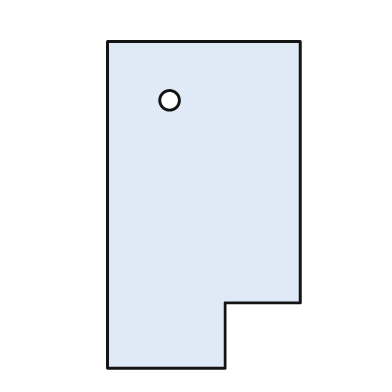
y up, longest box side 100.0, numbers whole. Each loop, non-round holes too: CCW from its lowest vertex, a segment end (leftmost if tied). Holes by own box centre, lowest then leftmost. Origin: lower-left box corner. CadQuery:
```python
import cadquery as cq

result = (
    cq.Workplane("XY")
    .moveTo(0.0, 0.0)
    .lineTo(36.0, 0.0)
    .lineTo(36.0, 20.0)
    .lineTo(59.0, 20.0)
    .lineTo(59.0, 100.0)
    .lineTo(0.0, 100.0)
    .close()
    .moveTo(19.0, 82.0)
    .circle(3.0)
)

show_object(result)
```